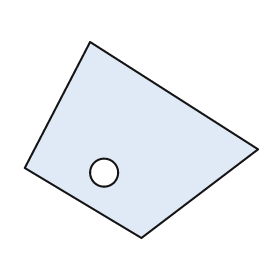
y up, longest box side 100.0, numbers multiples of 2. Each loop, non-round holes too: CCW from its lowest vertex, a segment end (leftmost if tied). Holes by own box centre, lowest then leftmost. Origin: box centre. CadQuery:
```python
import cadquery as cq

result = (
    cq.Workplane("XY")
    .moveTo(0.0, -42.0)
    .lineTo(50.0, -4.0)
    .lineTo(-22.0, 42.0)
    .lineTo(-50.0, -12.0)
    .close()
    .moveTo(-16.0, -14.0)
    .circle(6.0)
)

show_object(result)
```